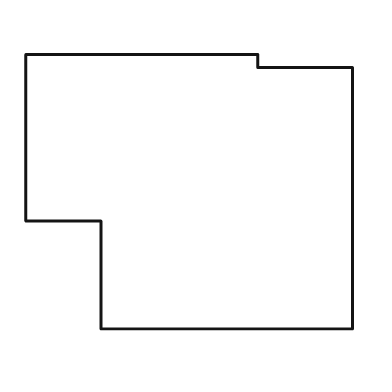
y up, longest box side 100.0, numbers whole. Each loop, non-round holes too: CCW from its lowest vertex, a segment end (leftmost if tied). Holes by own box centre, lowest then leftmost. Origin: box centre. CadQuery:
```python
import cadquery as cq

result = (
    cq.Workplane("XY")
    .moveTo(-27.0, -42.0)
    .lineTo(50.0, -42.0)
    .lineTo(50.0, 38.0)
    .lineTo(21.0, 38.0)
    .lineTo(21.0, 42.0)
    .lineTo(-50.0, 42.0)
    .lineTo(-50.0, -9.0)
    .lineTo(-27.0, -9.0)
    .close()
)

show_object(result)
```